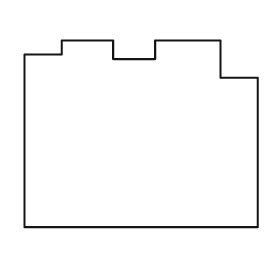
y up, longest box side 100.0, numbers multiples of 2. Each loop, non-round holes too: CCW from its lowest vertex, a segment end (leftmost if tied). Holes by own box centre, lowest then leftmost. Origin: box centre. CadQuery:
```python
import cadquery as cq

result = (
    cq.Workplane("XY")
    .moveTo(-50.0, -40.0)
    .lineTo(50.0, -40.0)
    .lineTo(50.0, 24.0)
    .lineTo(34.0, 24.0)
    .lineTo(34.0, 40.0)
    .lineTo(6.0, 40.0)
    .lineTo(6.0, 32.0)
    .lineTo(-12.0, 32.0)
    .lineTo(-12.0, 40.0)
    .lineTo(-34.0, 40.0)
    .lineTo(-34.0, 34.0)
    .lineTo(-50.0, 34.0)
    .close()
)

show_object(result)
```